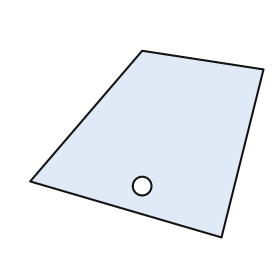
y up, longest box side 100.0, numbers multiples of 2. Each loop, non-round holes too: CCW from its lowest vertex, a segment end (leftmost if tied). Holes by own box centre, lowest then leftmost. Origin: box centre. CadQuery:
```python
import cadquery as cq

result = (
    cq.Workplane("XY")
    .moveTo(32.0, -40.0)
    .lineTo(50.0, 32.0)
    .lineTo(-2.0, 40.0)
    .lineTo(-50.0, -16.0)
    .close()
    .moveTo(-2.0, -18.0)
    .circle(4.0)
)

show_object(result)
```